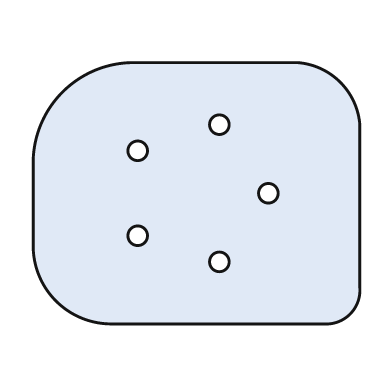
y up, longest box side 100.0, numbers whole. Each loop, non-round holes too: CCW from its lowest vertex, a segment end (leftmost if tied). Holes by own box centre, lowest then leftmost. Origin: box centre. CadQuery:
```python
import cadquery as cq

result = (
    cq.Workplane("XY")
    .moveTo(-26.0, -40.0)
    .lineTo(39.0, -40.0)
    .threePointArc((47.0, -37.0), (50.0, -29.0))
    .lineTo(50.0, 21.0)
    .threePointArc((44.0, 34.0), (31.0, 40.0))
    .lineTo(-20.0, 40.0)
    .threePointArc((-41.0, 31.0), (-50.0, 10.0))
    .lineTo(-50.0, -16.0)
    .threePointArc((-43.0, -33.0), (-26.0, -40.0))
    .close()
    .moveTo(7.0, -21.0)
    .circle(3.0)
    .moveTo(-18.0, -13.0)
    .circle(3.0)
    .moveTo(22.0, 0.0)
    .circle(3.0)
    .moveTo(-18.0, 13.0)
    .circle(3.0)
    .moveTo(7.0, 21.0)
    .circle(3.0)
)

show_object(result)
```